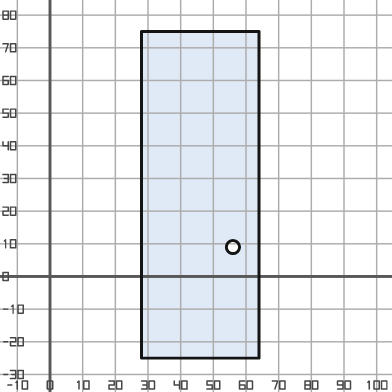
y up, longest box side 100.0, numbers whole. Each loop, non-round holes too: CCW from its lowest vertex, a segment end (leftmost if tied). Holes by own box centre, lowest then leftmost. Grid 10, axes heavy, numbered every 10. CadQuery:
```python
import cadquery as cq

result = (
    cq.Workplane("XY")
    .moveTo(28.0, -25.0)
    .lineTo(64.0, -25.0)
    .lineTo(64.0, 75.0)
    .lineTo(28.0, 75.0)
    .close()
    .moveTo(56.0, 9.0)
    .circle(2.0)
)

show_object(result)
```